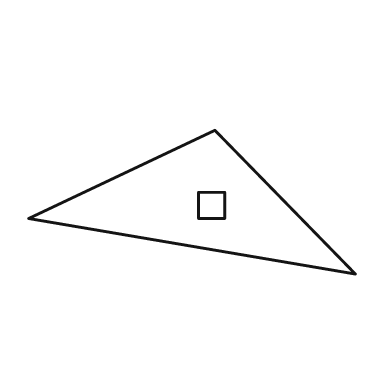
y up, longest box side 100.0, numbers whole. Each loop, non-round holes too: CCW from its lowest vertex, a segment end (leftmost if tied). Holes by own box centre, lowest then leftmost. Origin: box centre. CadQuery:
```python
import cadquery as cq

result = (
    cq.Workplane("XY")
    .moveTo(50.0, -22.0)
    .lineTo(7.0, 22.0)
    .lineTo(-50.0, -5.0)
    .close()
    .moveTo(2.0, -5.0)
    .lineTo(10.0, -5.0)
    .lineTo(10.0, 3.0)
    .lineTo(2.0, 3.0)
    .close()
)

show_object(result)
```